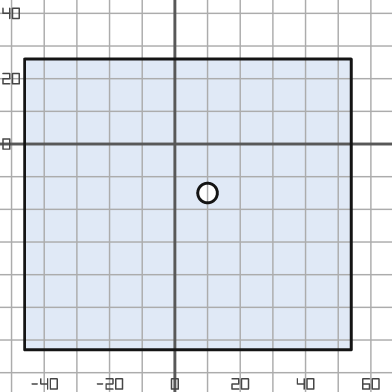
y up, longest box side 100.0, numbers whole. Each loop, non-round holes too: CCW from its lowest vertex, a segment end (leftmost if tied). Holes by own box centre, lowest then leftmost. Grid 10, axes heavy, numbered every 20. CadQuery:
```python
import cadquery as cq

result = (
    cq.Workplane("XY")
    .moveTo(-46.0, -63.0)
    .lineTo(54.0, -63.0)
    .lineTo(54.0, 26.0)
    .lineTo(-46.0, 26.0)
    .close()
    .moveTo(10.0, -15.0)
    .circle(3.0)
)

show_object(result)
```